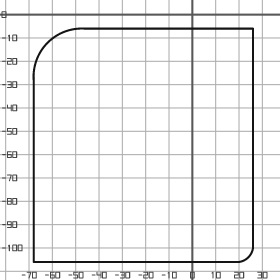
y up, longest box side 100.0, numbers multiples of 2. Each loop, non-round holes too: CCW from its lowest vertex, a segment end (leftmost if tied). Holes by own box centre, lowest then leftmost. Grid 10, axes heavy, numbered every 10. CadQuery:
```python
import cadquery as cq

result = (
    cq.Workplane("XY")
    .moveTo(-68.0, -106.0)
    .lineTo(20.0, -106.0)
    .threePointArc((24.0, -104.0), (26.0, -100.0))
    .lineTo(26.0, -6.0)
    .lineTo(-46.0, -6.0)
    .threePointArc((-62.0, -12.0), (-68.0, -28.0))
    .close()
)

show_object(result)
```